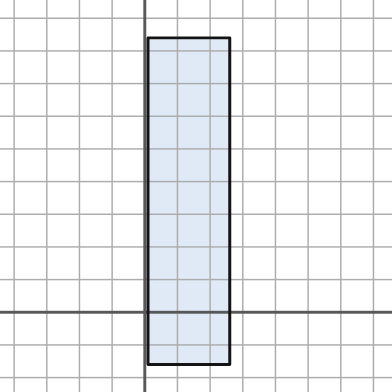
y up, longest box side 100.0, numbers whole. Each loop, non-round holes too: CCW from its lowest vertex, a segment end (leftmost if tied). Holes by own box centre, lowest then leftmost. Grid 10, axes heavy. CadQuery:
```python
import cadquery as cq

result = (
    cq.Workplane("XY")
    .moveTo(1.0, -16.0)
    .lineTo(26.0, -16.0)
    .lineTo(26.0, 84.0)
    .lineTo(1.0, 84.0)
    .close()
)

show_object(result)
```